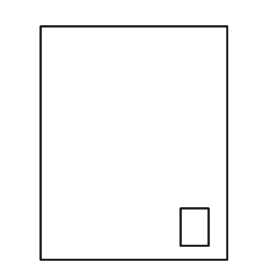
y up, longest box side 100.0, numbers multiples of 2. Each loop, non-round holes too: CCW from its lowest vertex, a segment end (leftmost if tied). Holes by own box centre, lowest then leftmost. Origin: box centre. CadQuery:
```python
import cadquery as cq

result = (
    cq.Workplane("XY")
    .moveTo(-40.0, -50.0)
    .lineTo(40.0, -50.0)
    .lineTo(40.0, 50.0)
    .lineTo(-40.0, 50.0)
    .close()
    .moveTo(20.0, -44.0)
    .lineTo(32.0, -44.0)
    .lineTo(32.0, -28.0)
    .lineTo(20.0, -28.0)
    .close()
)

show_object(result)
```